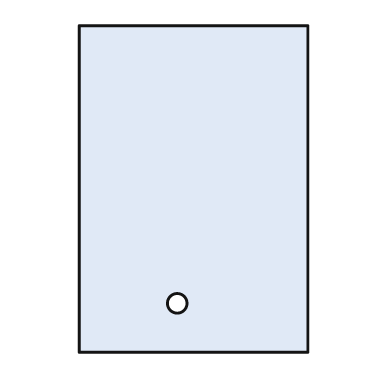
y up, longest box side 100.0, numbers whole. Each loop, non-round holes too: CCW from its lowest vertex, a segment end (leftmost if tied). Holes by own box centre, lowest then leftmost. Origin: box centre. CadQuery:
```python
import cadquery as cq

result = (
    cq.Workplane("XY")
    .moveTo(-35.0, -50.0)
    .lineTo(35.0, -50.0)
    .lineTo(35.0, 50.0)
    .lineTo(-35.0, 50.0)
    .close()
    .moveTo(-5.0, -35.0)
    .circle(3.0)
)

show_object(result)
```